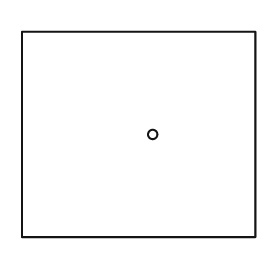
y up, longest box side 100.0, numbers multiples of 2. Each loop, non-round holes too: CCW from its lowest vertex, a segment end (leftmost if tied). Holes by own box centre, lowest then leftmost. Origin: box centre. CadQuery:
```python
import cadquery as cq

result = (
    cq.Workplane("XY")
    .moveTo(-50.0, -44.0)
    .lineTo(50.0, -44.0)
    .lineTo(50.0, 44.0)
    .lineTo(-50.0, 44.0)
    .close()
    .moveTo(6.0, 0.0)
    .circle(2.0)
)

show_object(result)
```